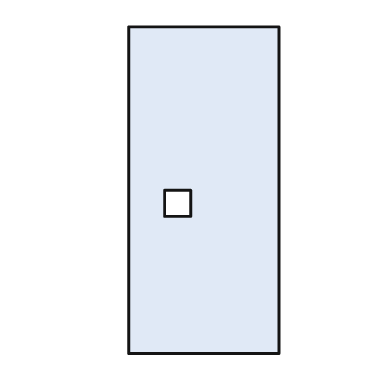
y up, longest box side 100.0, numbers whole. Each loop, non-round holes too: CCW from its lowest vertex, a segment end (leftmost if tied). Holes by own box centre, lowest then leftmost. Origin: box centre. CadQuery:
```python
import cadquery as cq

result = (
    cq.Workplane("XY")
    .moveTo(-23.0, -50.0)
    .lineTo(23.0, -50.0)
    .lineTo(23.0, 50.0)
    .lineTo(-23.0, 50.0)
    .close()
    .moveTo(-12.0, -8.0)
    .lineTo(-4.0, -8.0)
    .lineTo(-4.0, 0.0)
    .lineTo(-12.0, 0.0)
    .close()
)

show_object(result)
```